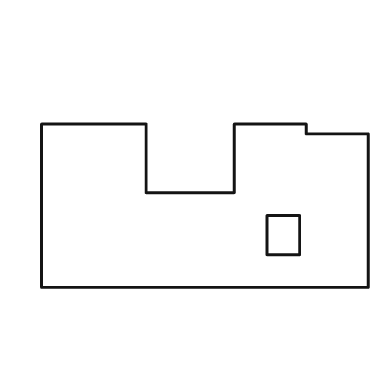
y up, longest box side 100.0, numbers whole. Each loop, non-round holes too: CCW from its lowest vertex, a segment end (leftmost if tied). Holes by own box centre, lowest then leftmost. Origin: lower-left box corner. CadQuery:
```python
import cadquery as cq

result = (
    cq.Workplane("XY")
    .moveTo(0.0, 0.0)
    .lineTo(100.0, 0.0)
    .lineTo(100.0, 47.0)
    .lineTo(81.0, 47.0)
    .lineTo(81.0, 50.0)
    .lineTo(59.0, 50.0)
    .lineTo(59.0, 29.0)
    .lineTo(32.0, 29.0)
    .lineTo(32.0, 50.0)
    .lineTo(0.0, 50.0)
    .close()
    .moveTo(69.0, 10.0)
    .lineTo(79.0, 10.0)
    .lineTo(79.0, 22.0)
    .lineTo(69.0, 22.0)
    .close()
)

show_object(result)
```